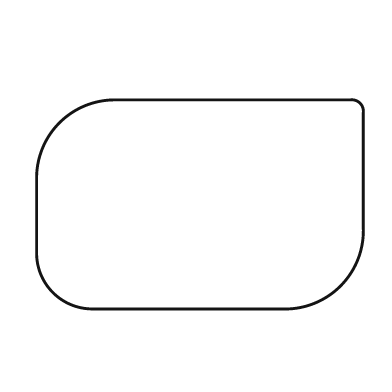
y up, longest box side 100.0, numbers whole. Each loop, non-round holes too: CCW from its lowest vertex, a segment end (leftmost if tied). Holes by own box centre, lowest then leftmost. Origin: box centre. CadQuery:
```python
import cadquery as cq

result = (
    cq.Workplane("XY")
    .moveTo(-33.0, -32.0)
    .lineTo(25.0, -32.0)
    .threePointArc((43.0, -25.0), (50.0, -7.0))
    .lineTo(50.0, 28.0)
    .threePointArc((49.0, 31.0), (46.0, 32.0))
    .lineTo(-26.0, 32.0)
    .threePointArc((-43.0, 25.0), (-50.0, 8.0))
    .lineTo(-50.0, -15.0)
    .threePointArc((-45.0, -27.0), (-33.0, -32.0))
    .close()
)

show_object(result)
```